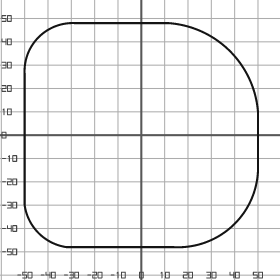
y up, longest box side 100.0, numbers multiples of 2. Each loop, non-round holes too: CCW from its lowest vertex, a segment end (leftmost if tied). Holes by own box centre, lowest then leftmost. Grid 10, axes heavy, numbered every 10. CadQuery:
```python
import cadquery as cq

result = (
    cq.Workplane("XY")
    .moveTo(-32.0, -48.0)
    .lineTo(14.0, -48.0)
    .threePointArc((40.0, -38.0), (50.0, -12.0))
    .lineTo(50.0, 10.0)
    .threePointArc((38.0, 36.0), (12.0, 48.0))
    .lineTo(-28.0, 48.0)
    .threePointArc((-44.0, 42.0), (-50.0, 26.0))
    .lineTo(-50.0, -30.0)
    .threePointArc((-44.0, -42.0), (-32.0, -48.0))
    .close()
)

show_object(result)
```